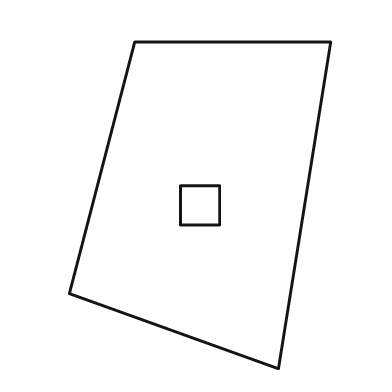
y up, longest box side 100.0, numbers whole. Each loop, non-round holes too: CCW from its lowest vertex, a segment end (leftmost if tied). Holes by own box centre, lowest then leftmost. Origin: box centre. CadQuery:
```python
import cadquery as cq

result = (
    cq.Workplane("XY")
    .moveTo(24.0, -50.0)
    .lineTo(40.0, 50.0)
    .lineTo(-20.0, 50.0)
    .lineTo(-40.0, -27.0)
    .close()
    .moveTo(-6.0, -6.0)
    .lineTo(6.0, -6.0)
    .lineTo(6.0, 6.0)
    .lineTo(-6.0, 6.0)
    .close()
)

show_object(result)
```